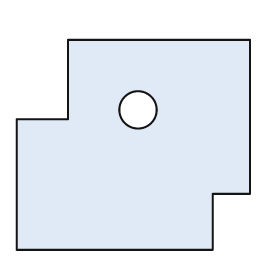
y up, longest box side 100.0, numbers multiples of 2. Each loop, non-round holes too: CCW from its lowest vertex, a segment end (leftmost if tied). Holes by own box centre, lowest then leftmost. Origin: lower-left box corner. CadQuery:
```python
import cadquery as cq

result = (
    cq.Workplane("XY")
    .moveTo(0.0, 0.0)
    .lineTo(84.0, 0.0)
    .lineTo(84.0, 24.0)
    .lineTo(100.0, 24.0)
    .lineTo(100.0, 90.0)
    .lineTo(22.0, 90.0)
    .lineTo(22.0, 56.0)
    .lineTo(0.0, 56.0)
    .close()
    .moveTo(52.0, 60.0)
    .circle(8.0)
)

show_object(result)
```